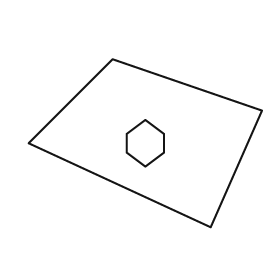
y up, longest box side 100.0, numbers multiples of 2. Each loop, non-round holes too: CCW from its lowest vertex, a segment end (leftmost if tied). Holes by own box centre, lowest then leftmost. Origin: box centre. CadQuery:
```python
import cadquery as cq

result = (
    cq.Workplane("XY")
    .moveTo(28.0, -36.0)
    .lineTo(50.0, 14.0)
    .lineTo(-14.0, 36.0)
    .lineTo(-50.0, 0.0)
    .close()
    .moveTo(0.0, -10.0)
    .lineTo(8.0, -4.0)
    .lineTo(8.0, 4.0)
    .lineTo(0.0, 10.0)
    .lineTo(-8.0, 4.0)
    .lineTo(-8.0, -4.0)
    .close()
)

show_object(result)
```